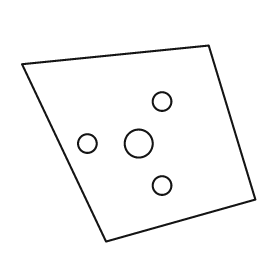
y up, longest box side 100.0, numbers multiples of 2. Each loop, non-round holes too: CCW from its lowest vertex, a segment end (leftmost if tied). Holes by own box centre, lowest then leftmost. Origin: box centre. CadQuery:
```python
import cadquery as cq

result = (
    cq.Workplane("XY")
    .moveTo(-14.0, -42.0)
    .lineTo(50.0, -24.0)
    .lineTo(30.0, 42.0)
    .lineTo(-50.0, 34.0)
    .close()
    .moveTo(10.0, -18.0)
    .circle(4.0)
    .moveTo(-22.0, 0.0)
    .circle(4.0)
    .moveTo(0.0, 0.0)
    .circle(6.0)
    .moveTo(10.0, 18.0)
    .circle(4.0)
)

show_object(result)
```